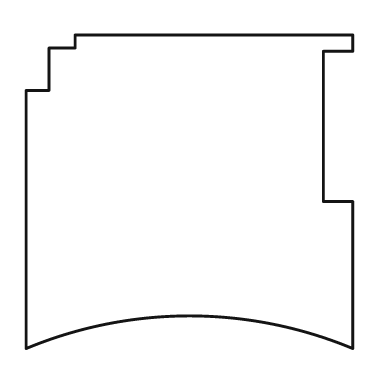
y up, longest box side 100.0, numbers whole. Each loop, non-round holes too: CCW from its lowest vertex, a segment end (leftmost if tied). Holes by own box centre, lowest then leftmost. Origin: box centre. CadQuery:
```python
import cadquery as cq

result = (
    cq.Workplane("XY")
    .moveTo(-50.0, -48.0)
    .threePointArc((0.0, -38.0), (50.0, -48.0))
    .lineTo(50.0, -3.0)
    .lineTo(41.0, -3.0)
    .lineTo(41.0, 43.0)
    .lineTo(50.0, 43.0)
    .lineTo(50.0, 48.0)
    .lineTo(-35.0, 48.0)
    .lineTo(-35.0, 44.0)
    .lineTo(-43.0, 44.0)
    .lineTo(-43.0, 31.0)
    .lineTo(-50.0, 31.0)
    .close()
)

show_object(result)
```